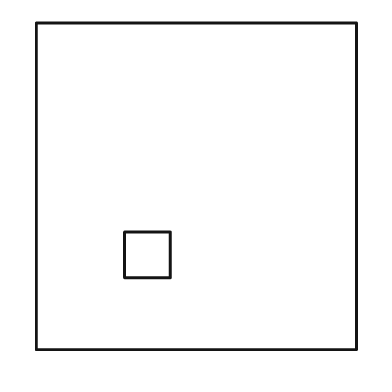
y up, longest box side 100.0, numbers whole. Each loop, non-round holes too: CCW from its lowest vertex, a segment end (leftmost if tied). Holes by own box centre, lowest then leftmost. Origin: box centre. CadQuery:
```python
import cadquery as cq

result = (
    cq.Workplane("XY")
    .moveTo(-49.0, -50.0)
    .lineTo(49.0, -50.0)
    .lineTo(49.0, 50.0)
    .lineTo(-49.0, 50.0)
    .close()
    .moveTo(-22.0, -28.0)
    .lineTo(-8.0, -28.0)
    .lineTo(-8.0, -14.0)
    .lineTo(-22.0, -14.0)
    .close()
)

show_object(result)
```